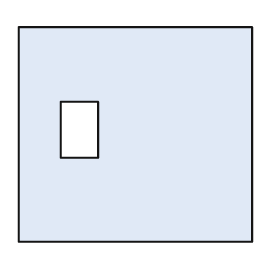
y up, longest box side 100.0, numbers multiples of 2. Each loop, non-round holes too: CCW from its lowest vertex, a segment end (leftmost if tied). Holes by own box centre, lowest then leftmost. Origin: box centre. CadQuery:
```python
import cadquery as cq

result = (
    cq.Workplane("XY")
    .moveTo(-50.0, -46.0)
    .lineTo(50.0, -46.0)
    .lineTo(50.0, 46.0)
    .lineTo(-50.0, 46.0)
    .close()
    .moveTo(-32.0, -10.0)
    .lineTo(-16.0, -10.0)
    .lineTo(-16.0, 14.0)
    .lineTo(-32.0, 14.0)
    .close()
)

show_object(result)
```